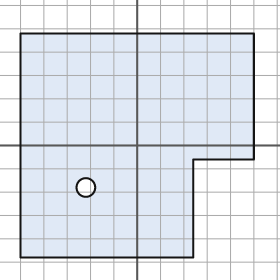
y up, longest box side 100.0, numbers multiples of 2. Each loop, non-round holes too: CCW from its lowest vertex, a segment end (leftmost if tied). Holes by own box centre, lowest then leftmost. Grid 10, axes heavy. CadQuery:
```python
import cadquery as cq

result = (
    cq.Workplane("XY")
    .moveTo(-50.0, -48.0)
    .lineTo(24.0, -48.0)
    .lineTo(24.0, -6.0)
    .lineTo(50.0, -6.0)
    .lineTo(50.0, 48.0)
    .lineTo(-50.0, 48.0)
    .close()
    .moveTo(-22.0, -18.0)
    .circle(4.0)
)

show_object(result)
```